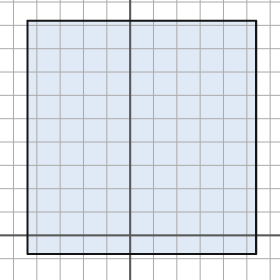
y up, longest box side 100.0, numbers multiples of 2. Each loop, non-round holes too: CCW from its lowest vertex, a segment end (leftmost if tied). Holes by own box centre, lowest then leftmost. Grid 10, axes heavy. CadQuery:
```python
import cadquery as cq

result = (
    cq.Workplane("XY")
    .moveTo(-44.0, -8.0)
    .lineTo(54.0, -8.0)
    .lineTo(54.0, 92.0)
    .lineTo(-44.0, 92.0)
    .close()
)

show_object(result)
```